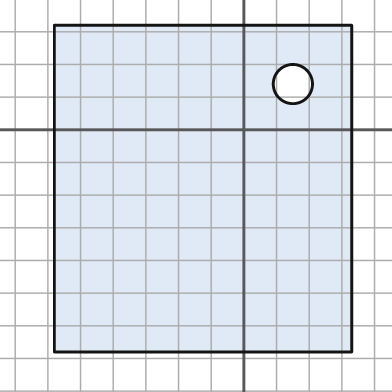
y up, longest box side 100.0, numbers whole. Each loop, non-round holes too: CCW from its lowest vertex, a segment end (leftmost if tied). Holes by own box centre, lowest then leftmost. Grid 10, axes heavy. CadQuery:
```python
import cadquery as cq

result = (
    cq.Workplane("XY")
    .moveTo(-58.0, -68.0)
    .lineTo(33.0, -68.0)
    .lineTo(33.0, 32.0)
    .lineTo(-58.0, 32.0)
    .close()
    .moveTo(15.0, 14.0)
    .circle(6.0)
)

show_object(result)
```